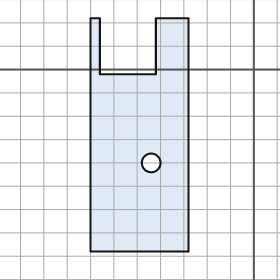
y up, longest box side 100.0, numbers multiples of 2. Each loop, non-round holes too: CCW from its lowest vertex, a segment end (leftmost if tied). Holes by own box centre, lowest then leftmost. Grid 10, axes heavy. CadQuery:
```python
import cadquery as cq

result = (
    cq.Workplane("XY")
    .moveTo(-70.0, -78.0)
    .lineTo(-28.0, -78.0)
    .lineTo(-28.0, 22.0)
    .lineTo(-42.0, 22.0)
    .lineTo(-42.0, -2.0)
    .lineTo(-66.0, -2.0)
    .lineTo(-66.0, 22.0)
    .lineTo(-70.0, 22.0)
    .close()
    .moveTo(-44.0, -40.0)
    .circle(4.0)
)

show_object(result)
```